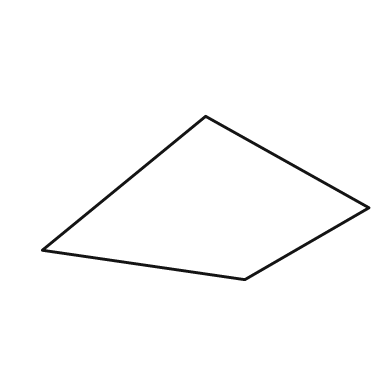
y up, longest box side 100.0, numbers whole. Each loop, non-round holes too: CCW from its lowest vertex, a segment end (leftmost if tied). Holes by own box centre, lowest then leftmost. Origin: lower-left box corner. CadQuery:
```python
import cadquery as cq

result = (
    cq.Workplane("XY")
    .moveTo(62.0, 0.0)
    .lineTo(100.0, 22.0)
    .lineTo(50.0, 50.0)
    .lineTo(0.0, 9.0)
    .close()
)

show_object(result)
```